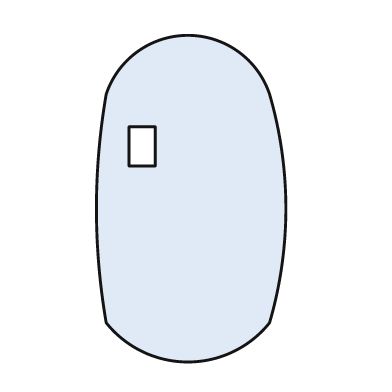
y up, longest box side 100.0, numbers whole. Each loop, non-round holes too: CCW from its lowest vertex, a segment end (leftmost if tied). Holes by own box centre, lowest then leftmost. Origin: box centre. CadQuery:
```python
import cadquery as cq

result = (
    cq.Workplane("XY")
    .moveTo(-26.0, -38.0)
    .threePointArc((-1.0, -50.0), (24.0, -38.0))
    .threePointArc((29.0, -3.0), (24.0, 32.0))
    .threePointArc((-1.0, 50.0), (-26.0, 32.0))
    .threePointArc((-29.0, -3.0), (-26.0, -38.0))
    .close()
    .moveTo(-19.0, 10.0)
    .lineTo(-11.0, 10.0)
    .lineTo(-11.0, 22.0)
    .lineTo(-19.0, 22.0)
    .close()
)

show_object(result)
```